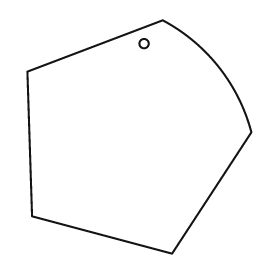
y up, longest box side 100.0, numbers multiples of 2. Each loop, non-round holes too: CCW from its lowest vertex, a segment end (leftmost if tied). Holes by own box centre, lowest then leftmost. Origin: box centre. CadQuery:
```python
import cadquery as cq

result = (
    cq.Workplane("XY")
    .moveTo(14.0, -50.0)
    .lineTo(48.0, 2.0)
    .threePointArc((34.0, 30.0), (10.0, 50.0))
    .lineTo(-48.0, 28.0)
    .lineTo(-46.0, -34.0)
    .close()
    .moveTo(2.0, 40.0)
    .circle(2.0)
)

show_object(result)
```